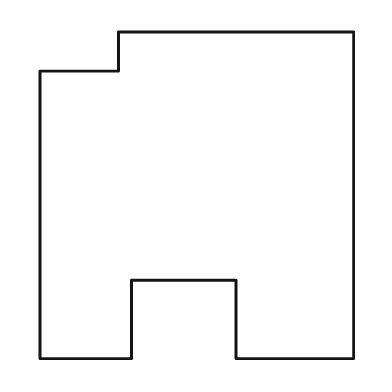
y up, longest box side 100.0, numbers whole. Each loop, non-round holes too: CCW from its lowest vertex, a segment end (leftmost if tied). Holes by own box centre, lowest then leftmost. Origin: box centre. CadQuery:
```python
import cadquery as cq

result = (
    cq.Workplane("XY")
    .moveTo(-48.0, -50.0)
    .lineTo(-20.0, -50.0)
    .lineTo(-20.0, -26.0)
    .lineTo(12.0, -26.0)
    .lineTo(12.0, -50.0)
    .lineTo(48.0, -50.0)
    .lineTo(48.0, 50.0)
    .lineTo(-24.0, 50.0)
    .lineTo(-24.0, 38.0)
    .lineTo(-48.0, 38.0)
    .close()
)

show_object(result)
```